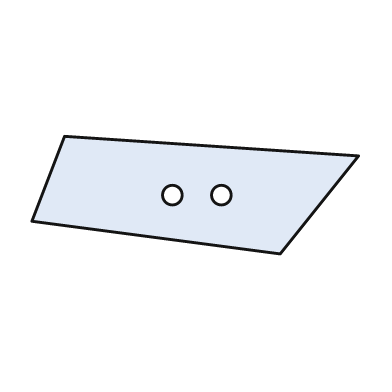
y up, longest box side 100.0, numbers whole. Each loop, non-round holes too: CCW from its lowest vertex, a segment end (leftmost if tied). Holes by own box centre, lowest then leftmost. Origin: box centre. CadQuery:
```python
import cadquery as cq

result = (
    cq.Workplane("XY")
    .moveTo(26.0, -18.0)
    .lineTo(50.0, 12.0)
    .lineTo(-40.0, 18.0)
    .lineTo(-50.0, -8.0)
    .close()
    .moveTo(-7.0, 0.0)
    .circle(3.0)
    .moveTo(8.0, 0.0)
    .circle(3.0)
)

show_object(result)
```